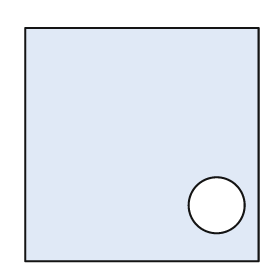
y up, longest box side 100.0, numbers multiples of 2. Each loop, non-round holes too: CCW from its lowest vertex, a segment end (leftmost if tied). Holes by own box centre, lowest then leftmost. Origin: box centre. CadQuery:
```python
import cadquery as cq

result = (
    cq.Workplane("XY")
    .moveTo(-50.0, -50.0)
    .lineTo(50.0, -50.0)
    .lineTo(50.0, 50.0)
    .lineTo(-50.0, 50.0)
    .close()
    .moveTo(32.0, -26.0)
    .circle(12.0)
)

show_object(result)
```